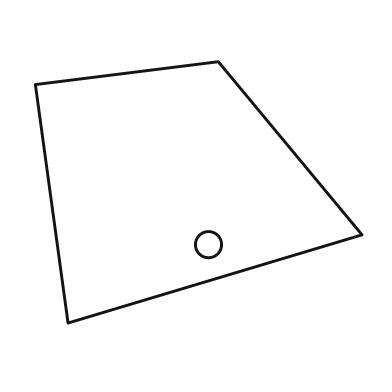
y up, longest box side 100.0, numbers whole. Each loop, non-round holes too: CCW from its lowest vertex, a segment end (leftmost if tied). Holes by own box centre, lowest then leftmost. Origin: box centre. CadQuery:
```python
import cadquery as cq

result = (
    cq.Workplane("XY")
    .moveTo(-40.0, -40.0)
    .lineTo(50.0, -13.0)
    .lineTo(6.0, 40.0)
    .lineTo(-50.0, 33.0)
    .close()
    .moveTo(3.0, -16.0)
    .circle(4.0)
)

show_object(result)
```